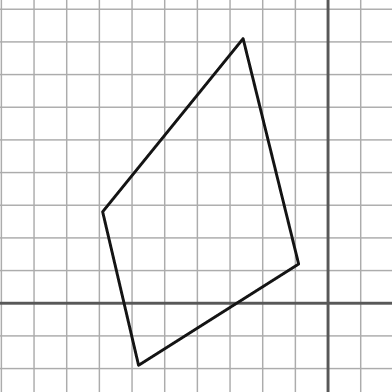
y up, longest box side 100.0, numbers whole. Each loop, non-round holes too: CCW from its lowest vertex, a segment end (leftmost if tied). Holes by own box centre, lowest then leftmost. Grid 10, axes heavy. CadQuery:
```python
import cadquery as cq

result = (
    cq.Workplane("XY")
    .moveTo(-58.0, -19.0)
    .lineTo(-9.0, 12.0)
    .lineTo(-26.0, 81.0)
    .lineTo(-69.0, 28.0)
    .close()
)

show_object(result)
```